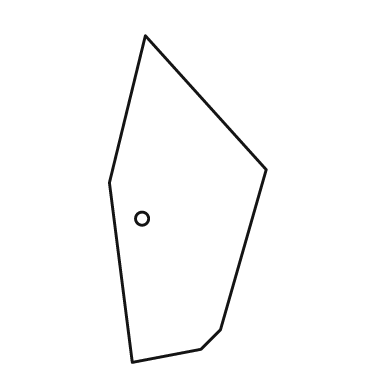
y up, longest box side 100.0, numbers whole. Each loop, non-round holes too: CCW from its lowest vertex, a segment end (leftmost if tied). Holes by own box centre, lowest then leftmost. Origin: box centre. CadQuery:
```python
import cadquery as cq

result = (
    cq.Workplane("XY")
    .moveTo(-17.0, -50.0)
    .lineTo(4.0, -46.0)
    .lineTo(10.0, -40.0)
    .lineTo(24.0, 9.0)
    .lineTo(-13.0, 50.0)
    .lineTo(-24.0, 5.0)
    .close()
    .moveTo(-14.0, -6.0)
    .circle(2.0)
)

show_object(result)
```